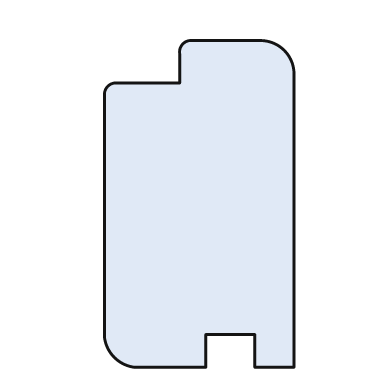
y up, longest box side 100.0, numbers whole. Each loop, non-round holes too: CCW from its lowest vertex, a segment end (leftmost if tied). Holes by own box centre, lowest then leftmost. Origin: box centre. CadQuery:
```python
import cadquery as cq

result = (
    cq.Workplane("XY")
    .moveTo(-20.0, -50.0)
    .lineTo(2.0, -50.0)
    .lineTo(2.0, -40.0)
    .lineTo(17.0, -40.0)
    .lineTo(17.0, -50.0)
    .lineTo(29.0, -50.0)
    .lineTo(29.0, 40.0)
    .threePointArc((26.0, 47.0), (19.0, 50.0))
    .lineTo(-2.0, 50.0)
    .threePointArc((-5.0, 49.0), (-6.0, 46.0))
    .lineTo(-6.0, 37.0)
    .lineTo(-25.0, 37.0)
    .threePointArc((-28.0, 36.0), (-29.0, 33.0))
    .lineTo(-29.0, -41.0)
    .threePointArc((-26.0, -47.0), (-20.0, -50.0))
    .close()
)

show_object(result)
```